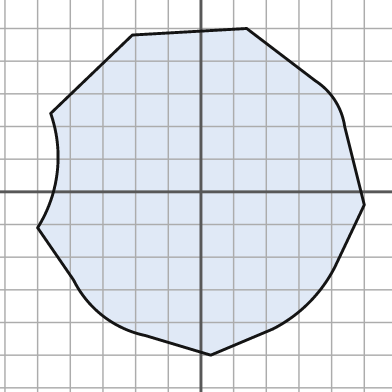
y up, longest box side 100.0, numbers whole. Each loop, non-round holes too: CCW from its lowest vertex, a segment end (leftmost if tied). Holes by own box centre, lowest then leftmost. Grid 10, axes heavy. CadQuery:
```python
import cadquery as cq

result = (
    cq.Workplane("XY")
    .moveTo(3.0, -50.0)
    .lineTo(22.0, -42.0)
    .threePointArc((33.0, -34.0), (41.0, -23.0))
    .lineTo(50.0, -4.0)
    .lineTo(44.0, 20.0)
    .threePointArc((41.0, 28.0), (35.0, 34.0))
    .lineTo(14.0, 50.0)
    .lineTo(-21.0, 48.0)
    .lineTo(-46.0, 24.0)
    .threePointArc((-44.0, 6.0), (-50.0, -11.0))
    .lineTo(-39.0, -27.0)
    .threePointArc((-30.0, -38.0), (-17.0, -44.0))
    .close()
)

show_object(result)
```